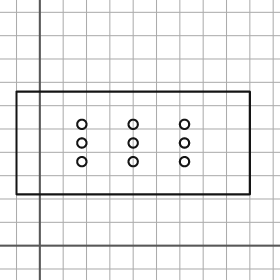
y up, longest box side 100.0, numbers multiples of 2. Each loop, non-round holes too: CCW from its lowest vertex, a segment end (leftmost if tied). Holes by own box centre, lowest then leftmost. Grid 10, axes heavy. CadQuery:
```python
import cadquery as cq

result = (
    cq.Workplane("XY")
    .moveTo(-10.0, 22.0)
    .lineTo(90.0, 22.0)
    .lineTo(90.0, 66.0)
    .lineTo(-10.0, 66.0)
    .close()
    .moveTo(18.0, 36.0)
    .circle(2.0)
    .moveTo(40.0, 36.0)
    .circle(2.0)
    .moveTo(62.0, 36.0)
    .circle(2.0)
    .moveTo(18.0, 44.0)
    .circle(2.0)
    .moveTo(40.0, 44.0)
    .circle(2.0)
    .moveTo(62.0, 44.0)
    .circle(2.0)
    .moveTo(18.0, 52.0)
    .circle(2.0)
    .moveTo(40.0, 52.0)
    .circle(2.0)
    .moveTo(62.0, 52.0)
    .circle(2.0)
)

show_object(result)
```